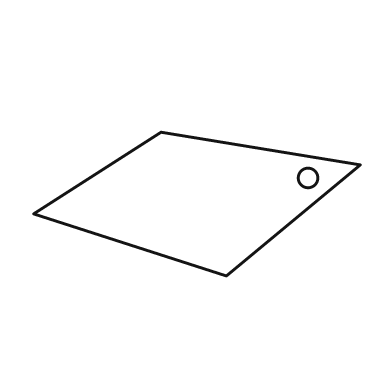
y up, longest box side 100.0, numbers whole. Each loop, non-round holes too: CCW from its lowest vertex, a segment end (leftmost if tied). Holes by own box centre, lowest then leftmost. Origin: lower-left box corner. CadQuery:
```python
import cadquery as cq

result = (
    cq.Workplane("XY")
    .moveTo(59.0, 0.0)
    .lineTo(100.0, 34.0)
    .lineTo(39.0, 44.0)
    .lineTo(0.0, 19.0)
    .close()
    .moveTo(84.0, 30.0)
    .circle(3.0)
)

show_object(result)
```